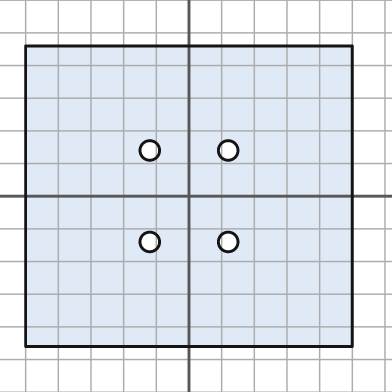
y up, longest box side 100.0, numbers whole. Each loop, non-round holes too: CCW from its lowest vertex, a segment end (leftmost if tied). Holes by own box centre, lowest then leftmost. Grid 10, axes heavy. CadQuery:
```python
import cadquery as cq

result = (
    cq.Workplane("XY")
    .moveTo(-50.0, -46.0)
    .lineTo(50.0, -46.0)
    .lineTo(50.0, 46.0)
    .lineTo(-50.0, 46.0)
    .close()
    .moveTo(-12.0, -14.0)
    .circle(3.0)
    .moveTo(12.0, -14.0)
    .circle(3.0)
    .moveTo(-12.0, 14.0)
    .circle(3.0)
    .moveTo(12.0, 14.0)
    .circle(3.0)
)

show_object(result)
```